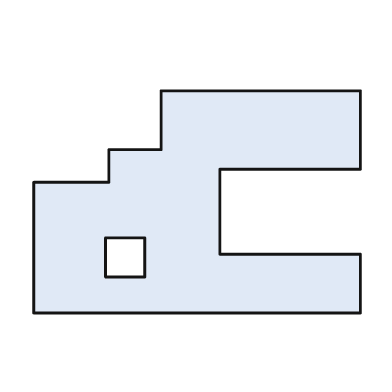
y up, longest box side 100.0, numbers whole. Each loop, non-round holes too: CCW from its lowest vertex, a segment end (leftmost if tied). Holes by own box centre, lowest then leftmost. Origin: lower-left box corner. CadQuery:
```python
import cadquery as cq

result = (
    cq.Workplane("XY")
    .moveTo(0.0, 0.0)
    .lineTo(100.0, 0.0)
    .lineTo(100.0, 18.0)
    .lineTo(57.0, 18.0)
    .lineTo(57.0, 44.0)
    .lineTo(100.0, 44.0)
    .lineTo(100.0, 68.0)
    .lineTo(39.0, 68.0)
    .lineTo(39.0, 50.0)
    .lineTo(23.0, 50.0)
    .lineTo(23.0, 40.0)
    .lineTo(0.0, 40.0)
    .close()
    .moveTo(22.0, 11.0)
    .lineTo(34.0, 11.0)
    .lineTo(34.0, 23.0)
    .lineTo(22.0, 23.0)
    .close()
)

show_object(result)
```